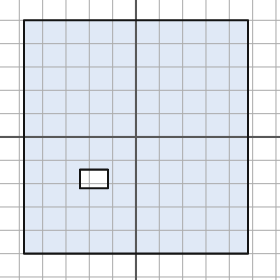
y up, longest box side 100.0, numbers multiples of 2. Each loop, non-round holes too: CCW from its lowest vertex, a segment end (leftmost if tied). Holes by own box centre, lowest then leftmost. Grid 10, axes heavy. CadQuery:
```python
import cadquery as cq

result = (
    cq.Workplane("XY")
    .moveTo(-48.0, -50.0)
    .lineTo(48.0, -50.0)
    .lineTo(48.0, 50.0)
    .lineTo(-48.0, 50.0)
    .close()
    .moveTo(-24.0, -22.0)
    .lineTo(-12.0, -22.0)
    .lineTo(-12.0, -14.0)
    .lineTo(-24.0, -14.0)
    .close()
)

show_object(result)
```